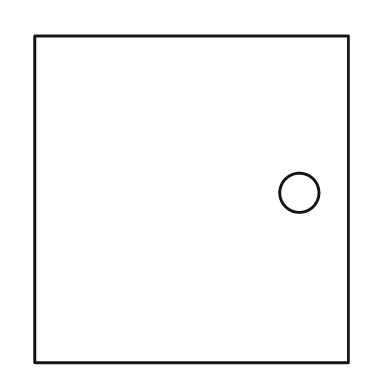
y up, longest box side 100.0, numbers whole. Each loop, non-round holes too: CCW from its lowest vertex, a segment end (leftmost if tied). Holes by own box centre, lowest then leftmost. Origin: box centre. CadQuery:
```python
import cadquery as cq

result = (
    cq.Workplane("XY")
    .moveTo(-48.0, -50.0)
    .lineTo(48.0, -50.0)
    .lineTo(48.0, 50.0)
    .lineTo(-48.0, 50.0)
    .close()
    .moveTo(33.0, 2.0)
    .circle(6.0)
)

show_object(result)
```